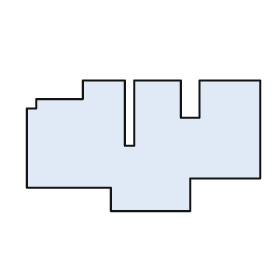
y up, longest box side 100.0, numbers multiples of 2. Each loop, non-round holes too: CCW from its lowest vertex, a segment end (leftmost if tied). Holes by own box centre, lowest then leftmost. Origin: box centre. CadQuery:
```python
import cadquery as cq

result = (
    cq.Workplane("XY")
    .moveTo(-14.0, -28.0)
    .lineTo(20.0, -28.0)
    .lineTo(20.0, -14.0)
    .lineTo(50.0, -14.0)
    .lineTo(50.0, 28.0)
    .lineTo(24.0, 28.0)
    .lineTo(24.0, 12.0)
    .lineTo(16.0, 12.0)
    .lineTo(16.0, 28.0)
    .lineTo(-4.0, 28.0)
    .lineTo(-4.0, 0.0)
    .lineTo(-8.0, 0.0)
    .lineTo(-8.0, 28.0)
    .lineTo(-26.0, 28.0)
    .lineTo(-26.0, 20.0)
    .lineTo(-46.0, 20.0)
    .lineTo(-46.0, 16.0)
    .lineTo(-50.0, 16.0)
    .lineTo(-50.0, -18.0)
    .lineTo(-14.0, -18.0)
    .close()
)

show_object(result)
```